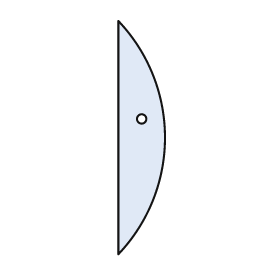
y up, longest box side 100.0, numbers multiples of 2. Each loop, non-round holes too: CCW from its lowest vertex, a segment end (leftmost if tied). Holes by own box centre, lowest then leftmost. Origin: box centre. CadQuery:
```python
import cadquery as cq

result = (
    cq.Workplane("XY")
    .moveTo(-10.0, -50.0)
    .threePointArc((10.0, 0.0), (-10.0, 50.0))
    .close()
    .moveTo(0.0, 8.0)
    .circle(2.0)
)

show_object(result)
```